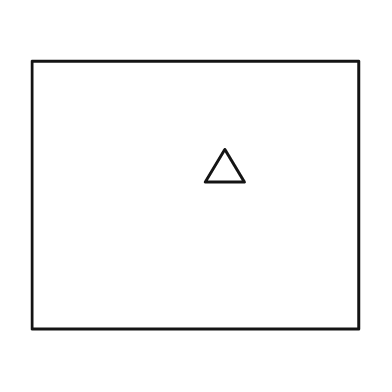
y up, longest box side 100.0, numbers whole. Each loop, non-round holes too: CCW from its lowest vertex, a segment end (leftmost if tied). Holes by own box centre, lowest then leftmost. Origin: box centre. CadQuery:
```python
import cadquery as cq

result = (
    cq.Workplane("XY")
    .moveTo(-50.0, -41.0)
    .lineTo(50.0, -41.0)
    .lineTo(50.0, 41.0)
    .lineTo(-50.0, 41.0)
    .close()
    .moveTo(3.0, 4.0)
    .lineTo(15.0, 4.0)
    .lineTo(9.0, 14.0)
    .close()
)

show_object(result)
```